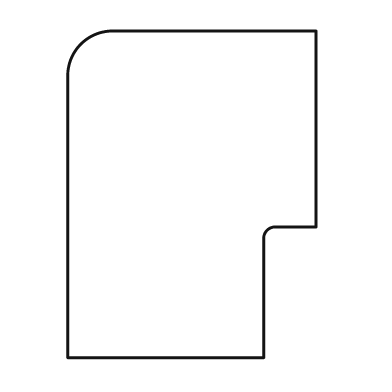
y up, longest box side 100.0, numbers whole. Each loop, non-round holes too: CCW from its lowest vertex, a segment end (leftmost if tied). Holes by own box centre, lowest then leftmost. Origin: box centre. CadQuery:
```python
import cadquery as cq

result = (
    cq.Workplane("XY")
    .moveTo(-38.0, -50.0)
    .lineTo(22.0, -50.0)
    .lineTo(22.0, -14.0)
    .threePointArc((23.0, -11.0), (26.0, -10.0))
    .lineTo(38.0, -10.0)
    .lineTo(38.0, 50.0)
    .lineTo(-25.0, 50.0)
    .threePointArc((-34.0, 46.0), (-38.0, 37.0))
    .close()
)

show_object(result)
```